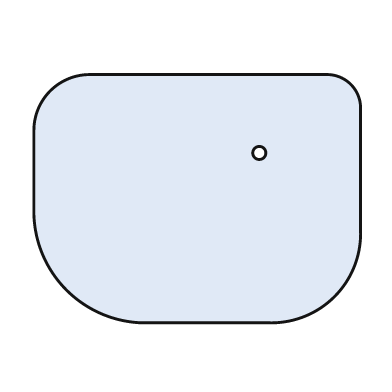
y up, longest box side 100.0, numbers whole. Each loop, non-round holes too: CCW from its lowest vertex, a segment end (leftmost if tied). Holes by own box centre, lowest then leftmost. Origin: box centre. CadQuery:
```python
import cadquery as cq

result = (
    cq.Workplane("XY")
    .moveTo(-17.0, -38.0)
    .lineTo(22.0, -38.0)
    .threePointArc((42.0, -30.0), (50.0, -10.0))
    .lineTo(50.0, 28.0)
    .threePointArc((47.0, 35.0), (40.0, 38.0))
    .lineTo(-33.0, 38.0)
    .threePointArc((-45.0, 33.0), (-50.0, 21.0))
    .lineTo(-50.0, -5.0)
    .threePointArc((-40.0, -28.0), (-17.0, -38.0))
    .close()
    .moveTo(19.0, 14.0)
    .circle(2.0)
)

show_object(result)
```